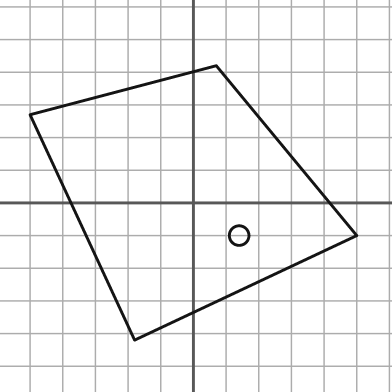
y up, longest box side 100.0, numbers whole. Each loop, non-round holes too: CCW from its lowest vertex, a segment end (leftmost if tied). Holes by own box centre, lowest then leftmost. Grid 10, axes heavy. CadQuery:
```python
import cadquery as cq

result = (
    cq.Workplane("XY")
    .moveTo(-18.0, -42.0)
    .lineTo(50.0, -10.0)
    .lineTo(7.0, 42.0)
    .lineTo(-50.0, 27.0)
    .close()
    .moveTo(14.0, -10.0)
    .circle(3.0)
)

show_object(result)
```